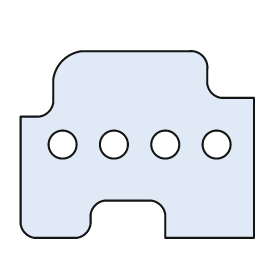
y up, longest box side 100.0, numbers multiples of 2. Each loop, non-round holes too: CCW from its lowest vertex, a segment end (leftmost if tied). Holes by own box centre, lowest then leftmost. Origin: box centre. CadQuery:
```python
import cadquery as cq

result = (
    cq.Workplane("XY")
    .moveTo(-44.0, -40.0)
    .lineTo(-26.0, -40.0)
    .threePointArc((-22.0, -38.0), (-20.0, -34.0))
    .lineTo(-20.0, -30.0)
    .threePointArc((-18.0, -26.0), (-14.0, -24.0))
    .lineTo(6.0, -24.0)
    .threePointArc((10.0, -26.0), (12.0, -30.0))
    .lineTo(12.0, -40.0)
    .lineTo(50.0, -40.0)
    .lineTo(50.0, 20.0)
    .lineTo(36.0, 20.0)
    .threePointArc((32.0, 22.0), (30.0, 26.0))
    .lineTo(30.0, 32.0)
    .threePointArc((28.0, 38.0), (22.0, 40.0))
    .lineTo(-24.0, 40.0)
    .threePointArc((-32.0, 36.0), (-36.0, 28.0))
    .lineTo(-36.0, 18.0)
    .threePointArc((-38.0, 14.0), (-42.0, 12.0))
    .lineTo(-50.0, 12.0)
    .lineTo(-50.0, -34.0)
    .threePointArc((-48.0, -38.0), (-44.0, -40.0))
    .close()
    .moveTo(-32.0, 0.0)
    .circle(6.0)
    .moveTo(-10.0, 0.0)
    .circle(6.0)
    .moveTo(12.0, 0.0)
    .circle(6.0)
    .moveTo(34.0, 0.0)
    .circle(6.0)
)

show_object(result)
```